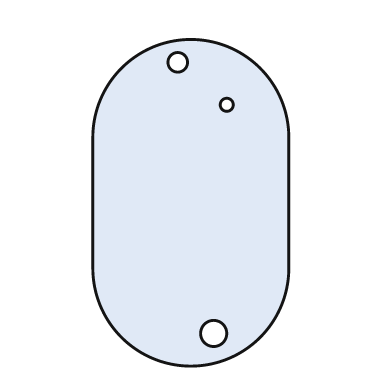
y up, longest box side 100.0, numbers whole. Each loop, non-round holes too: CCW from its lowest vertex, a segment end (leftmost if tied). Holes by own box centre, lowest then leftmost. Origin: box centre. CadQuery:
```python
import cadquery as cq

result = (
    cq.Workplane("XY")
    .moveTo(-30.0, -20.0)
    .threePointArc((0.0, -50.0), (30.0, -20.0))
    .lineTo(30.0, 20.0)
    .threePointArc((0.0, 50.0), (-30.0, 20.0))
    .close()
    .moveTo(7.0, -40.0)
    .circle(4.0)
    .moveTo(11.0, 30.0)
    .circle(2.0)
    .moveTo(-4.0, 43.0)
    .circle(3.0)
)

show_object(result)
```